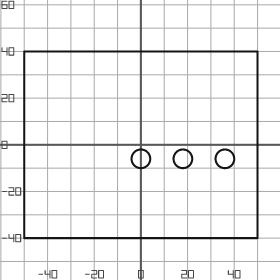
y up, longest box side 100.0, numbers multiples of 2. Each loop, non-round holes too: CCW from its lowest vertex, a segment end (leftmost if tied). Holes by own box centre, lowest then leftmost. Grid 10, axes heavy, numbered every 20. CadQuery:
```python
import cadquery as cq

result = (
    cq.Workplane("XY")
    .moveTo(-50.0, -40.0)
    .lineTo(50.0, -40.0)
    .lineTo(50.0, 40.0)
    .lineTo(-50.0, 40.0)
    .close()
    .moveTo(0.0, -6.0)
    .circle(4.0)
    .moveTo(18.0, -6.0)
    .circle(4.0)
    .moveTo(36.0, -6.0)
    .circle(4.0)
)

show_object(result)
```